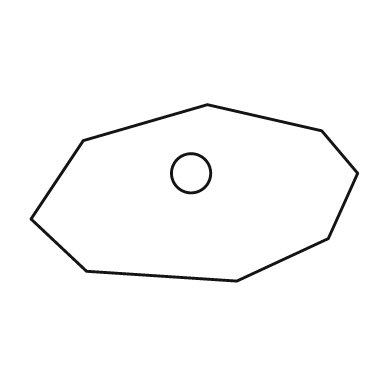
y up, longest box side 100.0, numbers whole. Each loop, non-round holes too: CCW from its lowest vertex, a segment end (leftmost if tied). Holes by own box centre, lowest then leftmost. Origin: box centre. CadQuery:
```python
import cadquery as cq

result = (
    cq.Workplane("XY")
    .moveTo(13.0, -27.0)
    .lineTo(41.0, -14.0)
    .lineTo(50.0, 6.0)
    .lineTo(39.0, 19.0)
    .lineTo(4.0, 27.0)
    .lineTo(-34.0, 16.0)
    .lineTo(-50.0, -8.0)
    .lineTo(-33.0, -24.0)
    .close()
    .moveTo(-1.0, 6.0)
    .circle(6.0)
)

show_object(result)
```